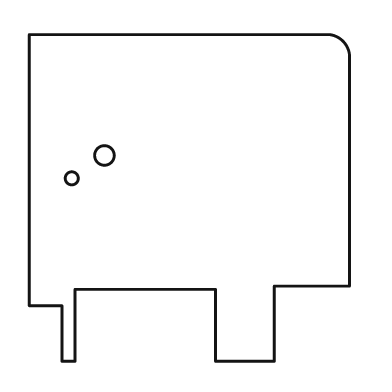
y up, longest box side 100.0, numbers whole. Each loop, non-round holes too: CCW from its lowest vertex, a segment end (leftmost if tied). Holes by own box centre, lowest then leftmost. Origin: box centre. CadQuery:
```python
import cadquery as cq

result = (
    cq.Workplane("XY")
    .moveTo(-39.0, -50.0)
    .lineTo(-35.0, -50.0)
    .lineTo(-35.0, -28.0)
    .lineTo(8.0, -28.0)
    .lineTo(8.0, -50.0)
    .lineTo(26.0, -50.0)
    .lineTo(26.0, -27.0)
    .lineTo(49.0, -27.0)
    .lineTo(49.0, 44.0)
    .threePointArc((47.0, 48.0), (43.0, 50.0))
    .lineTo(-49.0, 50.0)
    .lineTo(-49.0, -33.0)
    .lineTo(-39.0, -33.0)
    .close()
    .moveTo(-36.0, 6.0)
    .circle(2.0)
    .moveTo(-26.0, 13.0)
    .circle(3.0)
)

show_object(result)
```